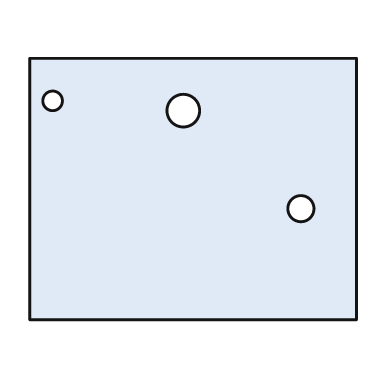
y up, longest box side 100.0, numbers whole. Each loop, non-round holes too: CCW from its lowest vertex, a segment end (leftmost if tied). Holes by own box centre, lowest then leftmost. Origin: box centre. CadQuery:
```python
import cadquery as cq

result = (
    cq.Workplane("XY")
    .moveTo(-50.0, -40.0)
    .lineTo(50.0, -40.0)
    .lineTo(50.0, 40.0)
    .lineTo(-50.0, 40.0)
    .close()
    .moveTo(33.0, -6.0)
    .circle(4.0)
    .moveTo(-3.0, 24.0)
    .circle(5.0)
    .moveTo(-43.0, 27.0)
    .circle(3.0)
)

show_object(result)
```